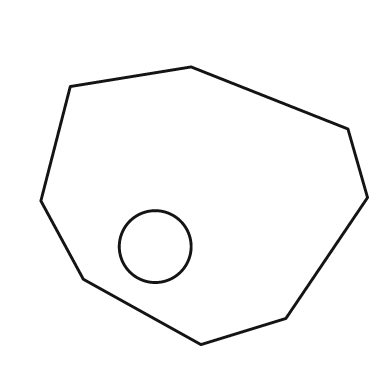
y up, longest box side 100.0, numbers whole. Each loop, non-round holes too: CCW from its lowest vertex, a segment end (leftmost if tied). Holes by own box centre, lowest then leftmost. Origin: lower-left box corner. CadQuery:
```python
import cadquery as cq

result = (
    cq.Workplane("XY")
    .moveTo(49.0, 0.0)
    .lineTo(75.0, 8.0)
    .lineTo(100.0, 45.0)
    .lineTo(94.0, 66.0)
    .lineTo(46.0, 85.0)
    .lineTo(9.0, 79.0)
    .lineTo(0.0, 44.0)
    .lineTo(13.0, 20.0)
    .close()
    .moveTo(35.0, 30.0)
    .circle(11.0)
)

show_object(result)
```